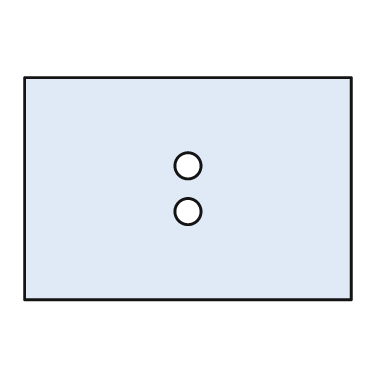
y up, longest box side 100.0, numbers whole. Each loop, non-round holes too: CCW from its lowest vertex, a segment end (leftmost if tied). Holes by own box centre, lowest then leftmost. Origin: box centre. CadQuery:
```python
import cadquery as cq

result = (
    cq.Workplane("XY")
    .moveTo(-50.0, -34.0)
    .lineTo(50.0, -34.0)
    .lineTo(50.0, 34.0)
    .lineTo(-50.0, 34.0)
    .close()
    .moveTo(0.0, -7.0)
    .circle(4.0)
    .moveTo(0.0, 7.0)
    .circle(4.0)
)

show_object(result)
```